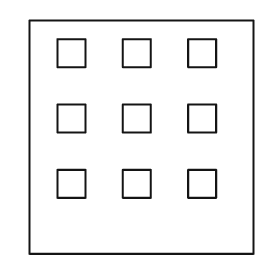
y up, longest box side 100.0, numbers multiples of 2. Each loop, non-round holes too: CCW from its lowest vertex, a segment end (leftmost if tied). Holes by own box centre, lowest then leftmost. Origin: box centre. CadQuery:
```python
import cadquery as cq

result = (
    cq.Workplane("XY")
    .moveTo(-48.0, -50.0)
    .lineTo(48.0, -50.0)
    .lineTo(48.0, 50.0)
    .lineTo(-48.0, 50.0)
    .close()
    .moveTo(-36.0, -26.0)
    .lineTo(-24.0, -26.0)
    .lineTo(-24.0, -14.0)
    .lineTo(-36.0, -14.0)
    .close()
    .moveTo(-8.0, -26.0)
    .lineTo(4.0, -26.0)
    .lineTo(4.0, -14.0)
    .lineTo(-8.0, -14.0)
    .close()
    .moveTo(20.0, -26.0)
    .lineTo(32.0, -26.0)
    .lineTo(32.0, -14.0)
    .lineTo(20.0, -14.0)
    .close()
    .moveTo(-36.0, 2.0)
    .lineTo(-24.0, 2.0)
    .lineTo(-24.0, 14.0)
    .lineTo(-36.0, 14.0)
    .close()
    .moveTo(-8.0, 2.0)
    .lineTo(4.0, 2.0)
    .lineTo(4.0, 14.0)
    .lineTo(-8.0, 14.0)
    .close()
    .moveTo(20.0, 2.0)
    .lineTo(32.0, 2.0)
    .lineTo(32.0, 14.0)
    .lineTo(20.0, 14.0)
    .close()
    .moveTo(-36.0, 30.0)
    .lineTo(-24.0, 30.0)
    .lineTo(-24.0, 42.0)
    .lineTo(-36.0, 42.0)
    .close()
    .moveTo(-8.0, 30.0)
    .lineTo(4.0, 30.0)
    .lineTo(4.0, 42.0)
    .lineTo(-8.0, 42.0)
    .close()
    .moveTo(20.0, 30.0)
    .lineTo(32.0, 30.0)
    .lineTo(32.0, 42.0)
    .lineTo(20.0, 42.0)
    .close()
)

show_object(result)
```